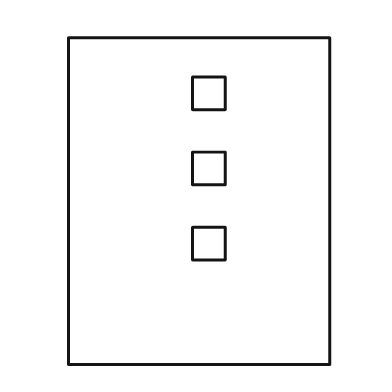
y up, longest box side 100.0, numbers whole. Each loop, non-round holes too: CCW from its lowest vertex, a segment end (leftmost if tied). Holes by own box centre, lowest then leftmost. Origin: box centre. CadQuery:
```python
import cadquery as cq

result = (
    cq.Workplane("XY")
    .moveTo(-40.0, -50.0)
    .lineTo(40.0, -50.0)
    .lineTo(40.0, 50.0)
    .lineTo(-40.0, 50.0)
    .close()
    .moveTo(-2.0, -18.0)
    .lineTo(8.0, -18.0)
    .lineTo(8.0, -8.0)
    .lineTo(-2.0, -8.0)
    .close()
    .moveTo(-2.0, 5.0)
    .lineTo(8.0, 5.0)
    .lineTo(8.0, 15.0)
    .lineTo(-2.0, 15.0)
    .close()
    .moveTo(-2.0, 28.0)
    .lineTo(8.0, 28.0)
    .lineTo(8.0, 38.0)
    .lineTo(-2.0, 38.0)
    .close()
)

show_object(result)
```